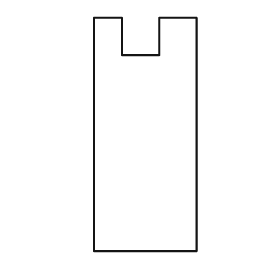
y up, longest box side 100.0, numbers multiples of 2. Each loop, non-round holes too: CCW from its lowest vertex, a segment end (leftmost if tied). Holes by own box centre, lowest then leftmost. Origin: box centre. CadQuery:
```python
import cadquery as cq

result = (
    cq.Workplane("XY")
    .moveTo(-22.0, -50.0)
    .lineTo(22.0, -50.0)
    .lineTo(22.0, 50.0)
    .lineTo(6.0, 50.0)
    .lineTo(6.0, 34.0)
    .lineTo(-10.0, 34.0)
    .lineTo(-10.0, 50.0)
    .lineTo(-22.0, 50.0)
    .close()
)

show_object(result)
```